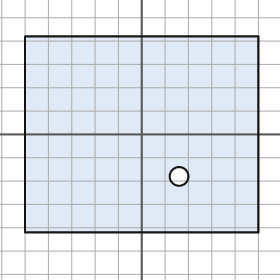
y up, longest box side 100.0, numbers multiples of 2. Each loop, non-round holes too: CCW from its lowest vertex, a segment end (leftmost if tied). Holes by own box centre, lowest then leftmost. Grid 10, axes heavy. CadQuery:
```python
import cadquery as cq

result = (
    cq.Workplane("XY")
    .moveTo(-50.0, -42.0)
    .lineTo(50.0, -42.0)
    .lineTo(50.0, 42.0)
    .lineTo(-50.0, 42.0)
    .close()
    .moveTo(16.0, -18.0)
    .circle(4.0)
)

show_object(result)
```